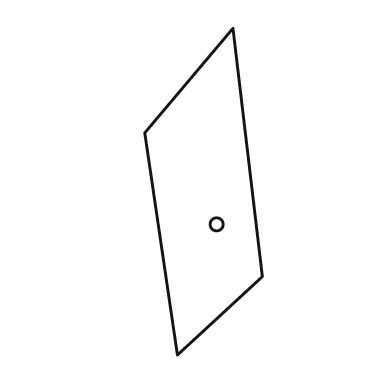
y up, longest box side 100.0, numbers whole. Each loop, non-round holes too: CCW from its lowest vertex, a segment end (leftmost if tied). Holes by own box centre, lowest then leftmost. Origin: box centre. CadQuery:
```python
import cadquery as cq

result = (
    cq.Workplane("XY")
    .moveTo(-8.0, -50.0)
    .lineTo(18.0, -26.0)
    .lineTo(9.0, 50.0)
    .lineTo(-18.0, 18.0)
    .close()
    .moveTo(4.0, -10.0)
    .circle(2.0)
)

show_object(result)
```